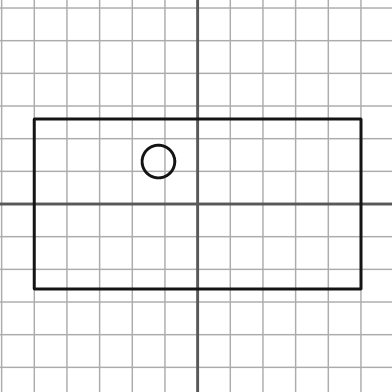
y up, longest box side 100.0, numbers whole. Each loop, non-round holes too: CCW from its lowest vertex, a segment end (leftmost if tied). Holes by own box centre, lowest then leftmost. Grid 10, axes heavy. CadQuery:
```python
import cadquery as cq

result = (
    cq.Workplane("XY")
    .moveTo(-50.0, -26.0)
    .lineTo(50.0, -26.0)
    .lineTo(50.0, 26.0)
    .lineTo(-50.0, 26.0)
    .close()
    .moveTo(-12.0, 13.0)
    .circle(5.0)
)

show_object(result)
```